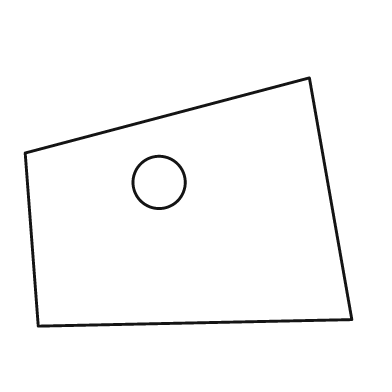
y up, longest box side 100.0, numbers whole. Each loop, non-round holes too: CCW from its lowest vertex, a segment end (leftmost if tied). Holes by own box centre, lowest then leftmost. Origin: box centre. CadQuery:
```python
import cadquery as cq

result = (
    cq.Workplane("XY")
    .moveTo(-46.0, -38.0)
    .lineTo(50.0, -36.0)
    .lineTo(37.0, 38.0)
    .lineTo(-50.0, 15.0)
    .close()
    .moveTo(-9.0, 6.0)
    .circle(8.0)
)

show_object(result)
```